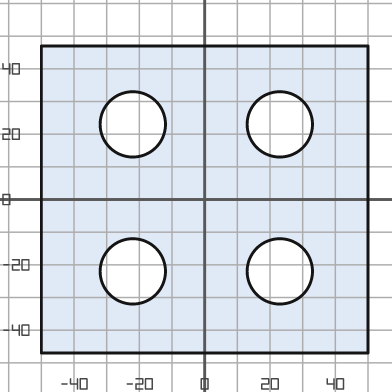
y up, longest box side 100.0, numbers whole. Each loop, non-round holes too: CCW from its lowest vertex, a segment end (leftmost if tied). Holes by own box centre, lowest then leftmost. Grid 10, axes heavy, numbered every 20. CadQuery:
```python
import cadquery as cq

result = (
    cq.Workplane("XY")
    .moveTo(-50.0, -47.0)
    .lineTo(50.0, -47.0)
    .lineTo(50.0, 47.0)
    .lineTo(-50.0, 47.0)
    .close()
    .moveTo(-22.0, -22.0)
    .circle(10.0)
    .moveTo(23.0, -22.0)
    .circle(10.0)
    .moveTo(-22.0, 23.0)
    .circle(10.0)
    .moveTo(23.0, 23.0)
    .circle(10.0)
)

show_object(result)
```